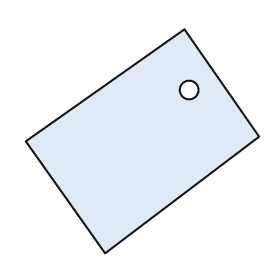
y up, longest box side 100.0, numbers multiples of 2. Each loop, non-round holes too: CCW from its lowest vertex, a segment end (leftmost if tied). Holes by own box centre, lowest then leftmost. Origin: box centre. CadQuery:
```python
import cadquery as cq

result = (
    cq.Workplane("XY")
    .moveTo(-16.0, -48.0)
    .lineTo(50.0, 2.0)
    .lineTo(18.0, 48.0)
    .lineTo(-50.0, 0.0)
    .close()
    .moveTo(20.0, 22.0)
    .circle(4.0)
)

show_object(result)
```